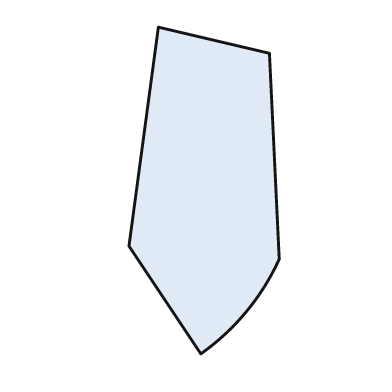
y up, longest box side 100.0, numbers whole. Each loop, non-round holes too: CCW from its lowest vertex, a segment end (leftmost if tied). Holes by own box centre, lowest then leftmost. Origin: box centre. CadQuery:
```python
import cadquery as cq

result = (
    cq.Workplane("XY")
    .moveTo(-1.0, -50.0)
    .threePointArc((13.0, -37.0), (23.0, -21.0))
    .lineTo(20.0, 42.0)
    .lineTo(-14.0, 50.0)
    .lineTo(-23.0, -17.0)
    .close()
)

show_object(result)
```